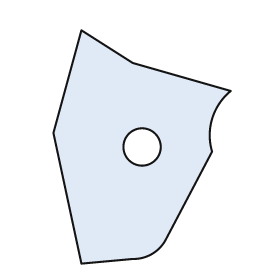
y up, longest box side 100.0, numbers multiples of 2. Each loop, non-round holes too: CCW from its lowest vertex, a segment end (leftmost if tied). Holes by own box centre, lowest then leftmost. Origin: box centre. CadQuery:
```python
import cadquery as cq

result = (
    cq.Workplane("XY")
    .moveTo(-26.0, -50.0)
    .lineTo(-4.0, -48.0)
    .threePointArc((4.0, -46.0), (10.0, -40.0))
    .lineTo(30.0, -2.0)
    .threePointArc((30.0, 12.0), (38.0, 24.0))
    .lineTo(-4.0, 36.0)
    .lineTo(-26.0, 50.0)
    .lineTo(-38.0, 6.0)
    .close()
    .moveTo(0.0, 0.0)
    .circle(8.0)
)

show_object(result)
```